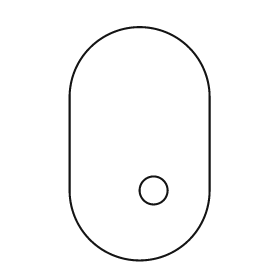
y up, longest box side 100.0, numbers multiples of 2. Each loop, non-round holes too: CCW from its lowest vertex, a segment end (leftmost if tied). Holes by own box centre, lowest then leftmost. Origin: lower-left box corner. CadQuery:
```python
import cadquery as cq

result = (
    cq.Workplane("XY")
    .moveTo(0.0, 30.0)
    .threePointArc((30.0, 0.0), (60.0, 30.0))
    .lineTo(60.0, 70.0)
    .threePointArc((30.0, 100.0), (0.0, 70.0))
    .close()
    .moveTo(36.0, 30.0)
    .circle(6.0)
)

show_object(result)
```